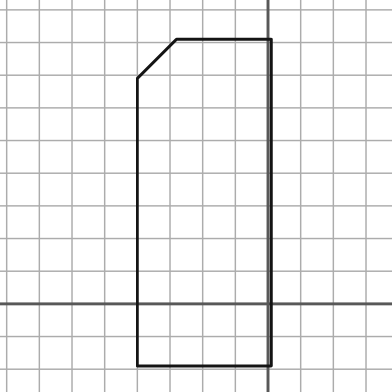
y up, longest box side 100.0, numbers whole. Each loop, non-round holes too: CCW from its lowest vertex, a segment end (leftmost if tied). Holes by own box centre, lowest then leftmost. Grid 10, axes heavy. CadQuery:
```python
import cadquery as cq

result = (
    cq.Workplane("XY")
    .moveTo(-40.0, -19.0)
    .lineTo(1.0, -19.0)
    .lineTo(1.0, 81.0)
    .lineTo(-28.0, 81.0)
    .lineTo(-40.0, 69.0)
    .close()
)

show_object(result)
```